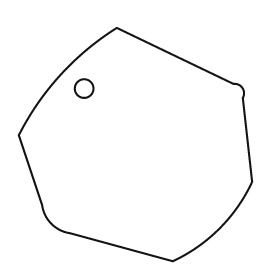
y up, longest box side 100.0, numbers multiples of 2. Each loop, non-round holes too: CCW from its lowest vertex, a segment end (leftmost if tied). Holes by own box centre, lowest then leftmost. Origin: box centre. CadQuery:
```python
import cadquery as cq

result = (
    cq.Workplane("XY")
    .moveTo(16.0, -50.0)
    .threePointArc((36.0, -36.0), (50.0, -16.0))
    .lineTo(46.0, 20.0)
    .threePointArc((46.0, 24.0), (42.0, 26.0))
    .lineTo(-8.0, 50.0)
    .threePointArc((-32.0, 30.0), (-50.0, 4.0))
    .lineTo(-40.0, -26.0)
    .threePointArc((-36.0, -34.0), (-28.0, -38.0))
    .close()
    .moveTo(-22.0, 24.0)
    .circle(4.0)
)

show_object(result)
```